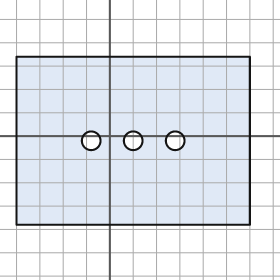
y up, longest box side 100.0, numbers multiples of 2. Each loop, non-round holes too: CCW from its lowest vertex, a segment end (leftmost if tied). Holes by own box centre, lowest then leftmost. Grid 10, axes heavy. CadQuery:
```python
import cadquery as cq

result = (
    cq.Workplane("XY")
    .moveTo(-40.0, -38.0)
    .lineTo(60.0, -38.0)
    .lineTo(60.0, 34.0)
    .lineTo(-40.0, 34.0)
    .close()
    .moveTo(-8.0, -2.0)
    .circle(4.0)
    .moveTo(10.0, -2.0)
    .circle(4.0)
    .moveTo(28.0, -2.0)
    .circle(4.0)
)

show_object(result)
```